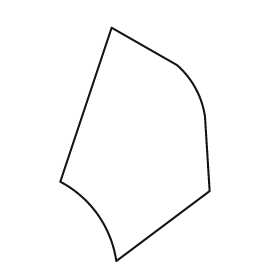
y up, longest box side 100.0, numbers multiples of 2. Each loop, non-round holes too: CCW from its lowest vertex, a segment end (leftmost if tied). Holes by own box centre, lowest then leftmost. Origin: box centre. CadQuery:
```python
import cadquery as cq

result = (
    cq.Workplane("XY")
    .moveTo(-8.0, -50.0)
    .lineTo(32.0, -20.0)
    .lineTo(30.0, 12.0)
    .threePointArc((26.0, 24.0), (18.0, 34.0))
    .lineTo(-10.0, 50.0)
    .lineTo(-32.0, -16.0)
    .threePointArc((-16.0, -30.0), (-8.0, -50.0))
    .close()
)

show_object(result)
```